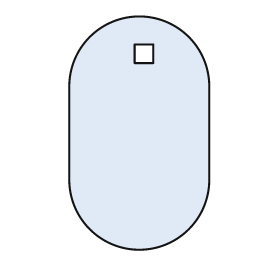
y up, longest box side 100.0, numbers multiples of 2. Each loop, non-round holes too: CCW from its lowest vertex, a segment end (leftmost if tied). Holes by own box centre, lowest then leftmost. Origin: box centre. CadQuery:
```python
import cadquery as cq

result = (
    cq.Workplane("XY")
    .moveTo(-30.0, -20.0)
    .threePointArc((0.0, -50.0), (30.0, -20.0))
    .lineTo(30.0, 20.0)
    .threePointArc((0.0, 50.0), (-30.0, 20.0))
    .close()
    .moveTo(-2.0, 30.0)
    .lineTo(6.0, 30.0)
    .lineTo(6.0, 38.0)
    .lineTo(-2.0, 38.0)
    .close()
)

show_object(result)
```